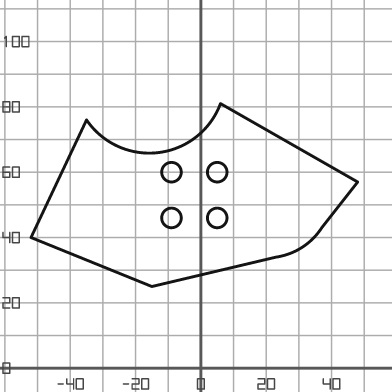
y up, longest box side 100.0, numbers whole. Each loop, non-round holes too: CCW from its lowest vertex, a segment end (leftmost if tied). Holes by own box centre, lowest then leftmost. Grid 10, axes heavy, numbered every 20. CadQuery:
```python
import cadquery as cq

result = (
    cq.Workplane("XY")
    .moveTo(-15.0, 25.0)
    .lineTo(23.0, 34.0)
    .threePointArc((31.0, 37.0), (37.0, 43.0))
    .lineTo(48.0, 57.0)
    .lineTo(6.0, 81.0)
    .threePointArc((-13.0, 66.0), (-35.0, 76.0))
    .lineTo(-52.0, 40.0)
    .close()
    .moveTo(-9.0, 46.0)
    .circle(3.0)
    .moveTo(5.0, 46.0)
    .circle(3.0)
    .moveTo(-9.0, 60.0)
    .circle(3.0)
    .moveTo(5.0, 60.0)
    .circle(3.0)
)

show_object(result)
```